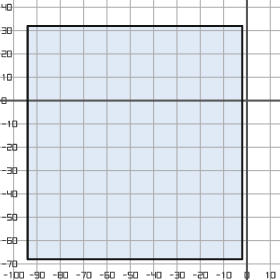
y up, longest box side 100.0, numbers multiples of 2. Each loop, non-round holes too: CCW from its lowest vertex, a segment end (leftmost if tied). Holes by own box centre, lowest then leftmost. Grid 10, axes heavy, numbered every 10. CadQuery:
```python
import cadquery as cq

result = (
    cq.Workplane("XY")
    .moveTo(-94.0, -68.0)
    .lineTo(-2.0, -68.0)
    .lineTo(-2.0, 32.0)
    .lineTo(-94.0, 32.0)
    .close()
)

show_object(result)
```